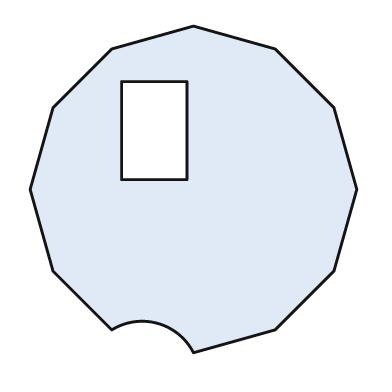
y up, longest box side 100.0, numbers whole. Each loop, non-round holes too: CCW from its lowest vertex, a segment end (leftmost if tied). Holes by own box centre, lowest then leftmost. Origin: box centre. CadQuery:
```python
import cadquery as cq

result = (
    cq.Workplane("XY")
    .moveTo(0.0, -50.0)
    .lineTo(25.0, -43.0)
    .lineTo(43.0, -25.0)
    .lineTo(50.0, 0.0)
    .lineTo(43.0, 25.0)
    .lineTo(25.0, 43.0)
    .lineTo(0.0, 50.0)
    .lineTo(-25.0, 43.0)
    .lineTo(-43.0, 25.0)
    .lineTo(-50.0, 0.0)
    .lineTo(-43.0, -25.0)
    .lineTo(-25.0, -43.0)
    .threePointArc((-11.0, -41.0), (0.0, -50.0))
    .close()
    .moveTo(-22.0, 3.0)
    .lineTo(-2.0, 3.0)
    .lineTo(-2.0, 33.0)
    .lineTo(-22.0, 33.0)
    .close()
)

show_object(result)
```